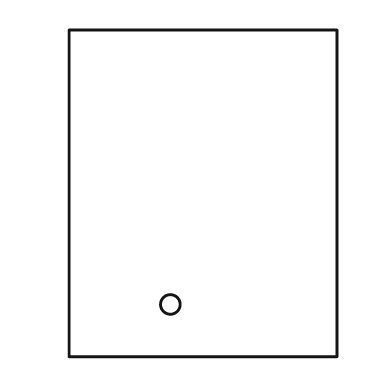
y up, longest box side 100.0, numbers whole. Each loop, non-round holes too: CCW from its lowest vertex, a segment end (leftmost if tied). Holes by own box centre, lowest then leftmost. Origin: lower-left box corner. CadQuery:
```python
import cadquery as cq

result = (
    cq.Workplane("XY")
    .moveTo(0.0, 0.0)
    .lineTo(82.0, 0.0)
    .lineTo(82.0, 100.0)
    .lineTo(0.0, 100.0)
    .close()
    .moveTo(31.0, 16.0)
    .circle(3.0)
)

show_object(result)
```